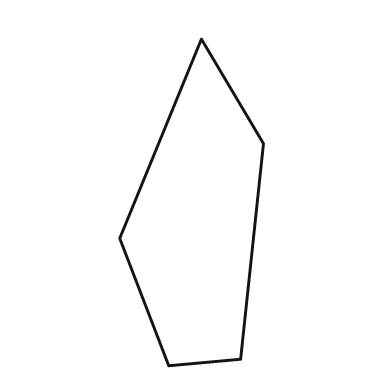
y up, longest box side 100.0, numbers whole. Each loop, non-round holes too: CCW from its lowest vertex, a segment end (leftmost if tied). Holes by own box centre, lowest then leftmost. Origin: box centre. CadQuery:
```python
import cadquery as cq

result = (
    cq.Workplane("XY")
    .moveTo(-7.0, -50.0)
    .lineTo(15.0, -48.0)
    .lineTo(22.0, 18.0)
    .lineTo(3.0, 50.0)
    .lineTo(-22.0, -11.0)
    .close()
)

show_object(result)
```